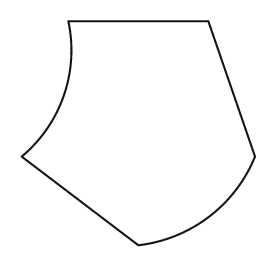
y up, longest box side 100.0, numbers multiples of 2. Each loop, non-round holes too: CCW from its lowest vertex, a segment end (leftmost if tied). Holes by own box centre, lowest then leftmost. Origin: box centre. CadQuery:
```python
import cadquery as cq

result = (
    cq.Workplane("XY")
    .moveTo(0.0, -48.0)
    .threePointArc((30.0, -36.0), (50.0, -10.0))
    .lineTo(30.0, 48.0)
    .lineTo(-30.0, 48.0)
    .threePointArc((-32.0, 16.0), (-50.0, -10.0))
    .close()
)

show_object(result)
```